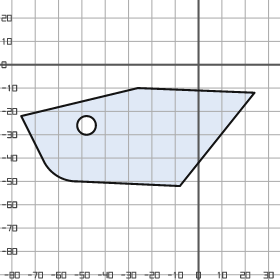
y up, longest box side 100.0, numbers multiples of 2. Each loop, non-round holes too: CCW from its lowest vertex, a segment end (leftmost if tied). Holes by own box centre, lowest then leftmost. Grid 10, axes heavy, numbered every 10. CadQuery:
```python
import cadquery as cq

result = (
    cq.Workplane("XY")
    .moveTo(-8.0, -52.0)
    .lineTo(24.0, -12.0)
    .lineTo(-26.0, -10.0)
    .lineTo(-76.0, -22.0)
    .lineTo(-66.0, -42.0)
    .threePointArc((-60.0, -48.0), (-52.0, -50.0))
    .close()
    .moveTo(-48.0, -26.0)
    .circle(4.0)
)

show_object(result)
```